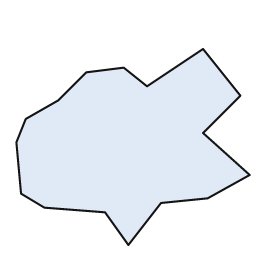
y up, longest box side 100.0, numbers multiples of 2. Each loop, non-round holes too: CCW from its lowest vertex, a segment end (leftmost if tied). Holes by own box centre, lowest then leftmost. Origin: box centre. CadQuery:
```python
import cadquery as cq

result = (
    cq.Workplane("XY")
    .moveTo(-2.0, -42.0)
    .lineTo(12.0, -24.0)
    .lineTo(32.0, -22.0)
    .lineTo(50.0, -12.0)
    .lineTo(30.0, 6.0)
    .lineTo(46.0, 22.0)
    .lineTo(30.0, 42.0)
    .lineTo(6.0, 26.0)
    .lineTo(-4.0, 34.0)
    .lineTo(-20.0, 32.0)
    .lineTo(-32.0, 20.0)
    .lineTo(-46.0, 12.0)
    .lineTo(-50.0, 2.0)
    .lineTo(-48.0, -20.0)
    .lineTo(-38.0, -26.0)
    .lineTo(-12.0, -28.0)
    .close()
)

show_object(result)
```